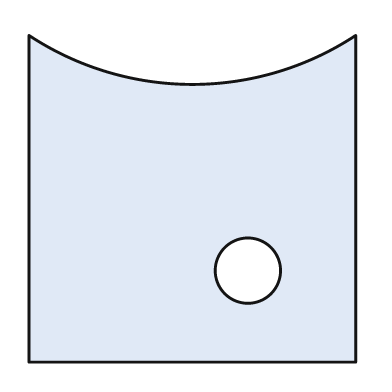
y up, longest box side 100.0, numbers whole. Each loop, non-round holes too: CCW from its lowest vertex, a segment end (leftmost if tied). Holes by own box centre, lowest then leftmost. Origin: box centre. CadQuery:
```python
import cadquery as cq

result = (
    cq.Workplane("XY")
    .moveTo(-50.0, -50.0)
    .lineTo(50.0, -50.0)
    .lineTo(50.0, 50.0)
    .threePointArc((0.0, 35.0), (-50.0, 50.0))
    .close()
    .moveTo(17.0, -22.0)
    .circle(10.0)
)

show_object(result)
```